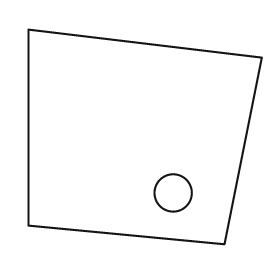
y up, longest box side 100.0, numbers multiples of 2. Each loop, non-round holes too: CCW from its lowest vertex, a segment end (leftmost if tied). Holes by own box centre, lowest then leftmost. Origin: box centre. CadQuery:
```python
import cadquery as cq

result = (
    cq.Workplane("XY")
    .moveTo(34.0, -46.0)
    .lineTo(50.0, 34.0)
    .lineTo(-50.0, 46.0)
    .lineTo(-50.0, -38.0)
    .close()
    .moveTo(12.0, -24.0)
    .circle(8.0)
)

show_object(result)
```